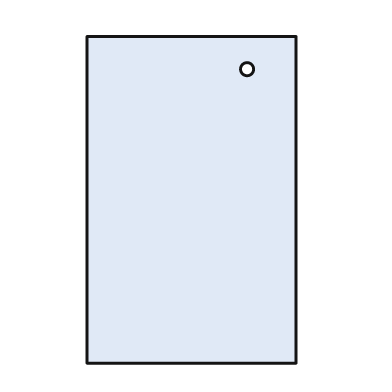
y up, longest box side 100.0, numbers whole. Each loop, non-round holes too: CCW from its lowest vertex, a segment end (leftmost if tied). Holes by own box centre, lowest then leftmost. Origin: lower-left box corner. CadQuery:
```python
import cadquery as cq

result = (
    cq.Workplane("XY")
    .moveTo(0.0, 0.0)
    .lineTo(64.0, 0.0)
    .lineTo(64.0, 100.0)
    .lineTo(0.0, 100.0)
    .close()
    .moveTo(49.0, 90.0)
    .circle(2.0)
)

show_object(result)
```